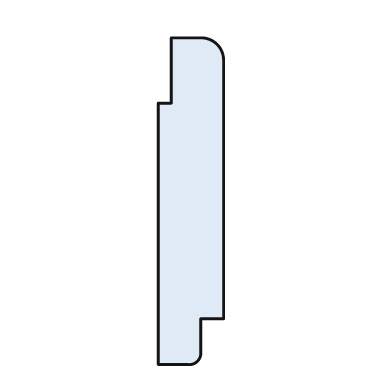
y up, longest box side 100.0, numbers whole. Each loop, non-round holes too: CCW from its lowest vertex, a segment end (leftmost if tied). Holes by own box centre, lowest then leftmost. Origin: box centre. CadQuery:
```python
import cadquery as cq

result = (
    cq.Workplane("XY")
    .moveTo(-10.0, -50.0)
    .lineTo(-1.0, -50.0)
    .threePointArc((2.0, -49.0), (3.0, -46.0))
    .lineTo(3.0, -36.0)
    .lineTo(10.0, -36.0)
    .lineTo(10.0, 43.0)
    .threePointArc((8.0, 48.0), (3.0, 50.0))
    .lineTo(-6.0, 50.0)
    .lineTo(-6.0, 30.0)
    .lineTo(-10.0, 30.0)
    .close()
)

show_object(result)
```